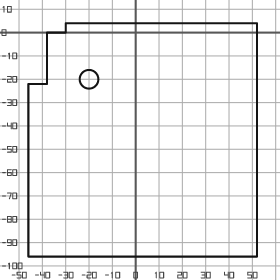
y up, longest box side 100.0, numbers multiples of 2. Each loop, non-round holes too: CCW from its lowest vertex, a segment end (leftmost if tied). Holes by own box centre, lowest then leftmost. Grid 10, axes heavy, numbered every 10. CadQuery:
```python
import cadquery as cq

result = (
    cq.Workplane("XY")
    .moveTo(-46.0, -96.0)
    .lineTo(52.0, -96.0)
    .lineTo(52.0, 4.0)
    .lineTo(-30.0, 4.0)
    .lineTo(-30.0, 0.0)
    .lineTo(-38.0, 0.0)
    .lineTo(-38.0, -22.0)
    .lineTo(-46.0, -22.0)
    .close()
    .moveTo(-20.0, -20.0)
    .circle(4.0)
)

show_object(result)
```